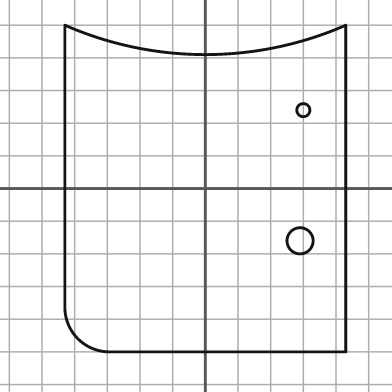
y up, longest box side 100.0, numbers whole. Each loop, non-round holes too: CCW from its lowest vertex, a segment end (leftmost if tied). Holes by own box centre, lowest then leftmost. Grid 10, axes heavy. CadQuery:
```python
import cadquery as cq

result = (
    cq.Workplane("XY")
    .moveTo(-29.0, -50.0)
    .lineTo(43.0, -50.0)
    .lineTo(43.0, 50.0)
    .threePointArc((0.0, 41.0), (-43.0, 50.0))
    .lineTo(-43.0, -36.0)
    .threePointArc((-39.0, -46.0), (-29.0, -50.0))
    .close()
    .moveTo(29.0, -16.0)
    .circle(4.0)
    .moveTo(30.0, 24.0)
    .circle(2.0)
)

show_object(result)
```